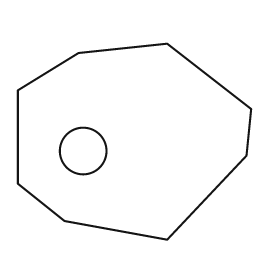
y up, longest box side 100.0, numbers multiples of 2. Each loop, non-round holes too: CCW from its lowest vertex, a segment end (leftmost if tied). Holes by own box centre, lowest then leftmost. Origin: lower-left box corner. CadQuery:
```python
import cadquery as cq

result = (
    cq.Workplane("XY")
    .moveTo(64.0, 0.0)
    .lineTo(98.0, 36.0)
    .lineTo(100.0, 56.0)
    .lineTo(64.0, 84.0)
    .lineTo(26.0, 80.0)
    .lineTo(0.0, 64.0)
    .lineTo(0.0, 24.0)
    .lineTo(20.0, 8.0)
    .close()
    .moveTo(28.0, 38.0)
    .circle(10.0)
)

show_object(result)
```